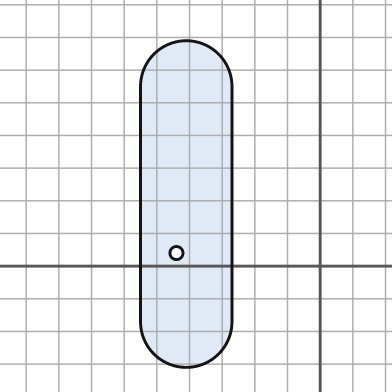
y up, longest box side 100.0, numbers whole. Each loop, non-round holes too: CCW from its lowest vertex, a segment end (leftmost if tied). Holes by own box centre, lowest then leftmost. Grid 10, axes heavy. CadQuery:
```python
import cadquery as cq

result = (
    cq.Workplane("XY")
    .moveTo(-55.0, -17.0)
    .threePointArc((-41.0, -31.0), (-27.0, -17.0))
    .lineTo(-27.0, 55.0)
    .threePointArc((-41.0, 69.0), (-55.0, 55.0))
    .close()
    .moveTo(-44.0, 4.0)
    .circle(2.0)
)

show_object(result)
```